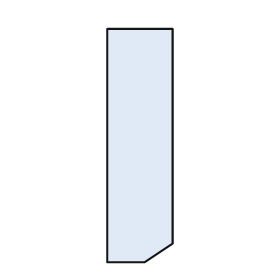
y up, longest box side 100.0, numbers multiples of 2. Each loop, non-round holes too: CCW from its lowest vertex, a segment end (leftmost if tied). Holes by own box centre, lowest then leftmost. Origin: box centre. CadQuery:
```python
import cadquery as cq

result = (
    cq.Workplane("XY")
    .moveTo(-14.0, -50.0)
    .lineTo(2.0, -50.0)
    .lineTo(14.0, -42.0)
    .lineTo(14.0, 50.0)
    .lineTo(-14.0, 50.0)
    .close()
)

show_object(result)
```